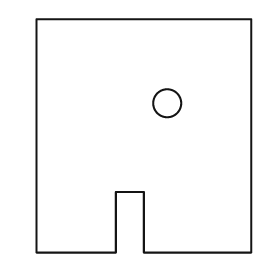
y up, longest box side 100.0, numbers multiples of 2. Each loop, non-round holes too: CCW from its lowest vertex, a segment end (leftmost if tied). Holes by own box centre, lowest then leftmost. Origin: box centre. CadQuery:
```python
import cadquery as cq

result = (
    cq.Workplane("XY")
    .moveTo(-46.0, -50.0)
    .lineTo(-12.0, -50.0)
    .lineTo(-12.0, -24.0)
    .lineTo(0.0, -24.0)
    .lineTo(0.0, -50.0)
    .lineTo(46.0, -50.0)
    .lineTo(46.0, 50.0)
    .lineTo(-46.0, 50.0)
    .close()
    .moveTo(10.0, 14.0)
    .circle(6.0)
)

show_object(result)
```